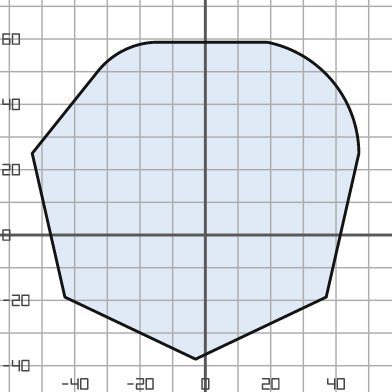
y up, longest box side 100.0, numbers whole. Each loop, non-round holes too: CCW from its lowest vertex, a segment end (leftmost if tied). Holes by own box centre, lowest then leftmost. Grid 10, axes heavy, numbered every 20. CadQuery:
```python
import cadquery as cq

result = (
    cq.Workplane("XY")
    .moveTo(-3.0, -38.0)
    .lineTo(37.0, -19.0)
    .lineTo(47.0, 25.0)
    .threePointArc((39.0, 47.0), (19.0, 59.0))
    .lineTo(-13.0, 59.0)
    .threePointArc((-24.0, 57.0), (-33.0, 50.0))
    .lineTo(-53.0, 25.0)
    .lineTo(-43.0, -19.0)
    .close()
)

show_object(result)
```